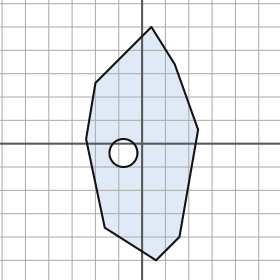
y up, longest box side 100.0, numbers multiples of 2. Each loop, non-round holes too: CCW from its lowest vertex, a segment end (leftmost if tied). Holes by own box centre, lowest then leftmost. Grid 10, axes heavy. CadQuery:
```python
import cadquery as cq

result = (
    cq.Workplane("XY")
    .moveTo(6.0, -50.0)
    .lineTo(16.0, -40.0)
    .lineTo(24.0, 6.0)
    .lineTo(14.0, 34.0)
    .lineTo(4.0, 50.0)
    .lineTo(-20.0, 26.0)
    .lineTo(-24.0, 2.0)
    .lineTo(-16.0, -36.0)
    .close()
    .moveTo(-8.0, -4.0)
    .circle(6.0)
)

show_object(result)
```